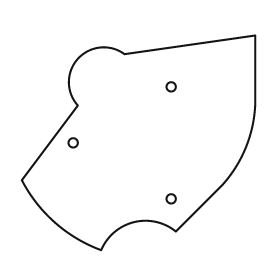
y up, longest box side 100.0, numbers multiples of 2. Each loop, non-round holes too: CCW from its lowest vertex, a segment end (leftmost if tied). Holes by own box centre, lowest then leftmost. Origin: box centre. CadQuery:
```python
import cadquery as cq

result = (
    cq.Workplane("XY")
    .moveTo(-16.0, -46.0)
    .threePointArc((-2.0, -34.0), (16.0, -38.0))
    .lineTo(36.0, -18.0)
    .threePointArc((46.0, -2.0), (50.0, 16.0))
    .lineTo(50.0, 46.0)
    .lineTo(-6.0, 38.0)
    .threePointArc((-26.0, 36.0), (-26.0, 16.0))
    .lineTo(-50.0, -16.0)
    .threePointArc((-36.0, -34.0), (-16.0, -46.0))
    .close()
    .moveTo(14.0, -24.0)
    .circle(2.0)
    .moveTo(-28.0, 0.0)
    .circle(2.0)
    .moveTo(14.0, 24.0)
    .circle(2.0)
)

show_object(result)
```